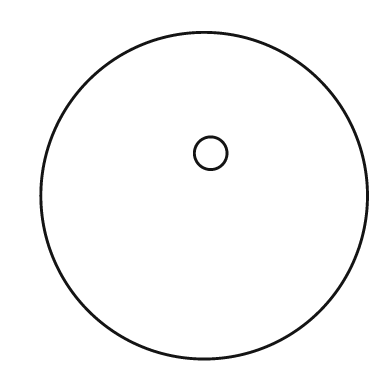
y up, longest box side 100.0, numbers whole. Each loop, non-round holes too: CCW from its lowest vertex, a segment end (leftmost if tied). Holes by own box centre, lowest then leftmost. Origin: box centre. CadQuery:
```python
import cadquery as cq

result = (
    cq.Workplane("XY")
    .moveTo(0.0, 0.0)
    .circle(50.0)
    .moveTo(2.0, 13.0)
    .circle(5.0)
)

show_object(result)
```